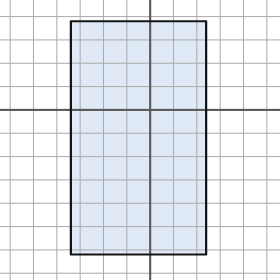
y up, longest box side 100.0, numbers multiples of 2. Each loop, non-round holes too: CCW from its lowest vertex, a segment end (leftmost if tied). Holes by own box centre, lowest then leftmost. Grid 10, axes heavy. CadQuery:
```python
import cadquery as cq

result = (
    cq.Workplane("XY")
    .moveTo(-34.0, -62.0)
    .lineTo(24.0, -62.0)
    .lineTo(24.0, 38.0)
    .lineTo(-34.0, 38.0)
    .close()
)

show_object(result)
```